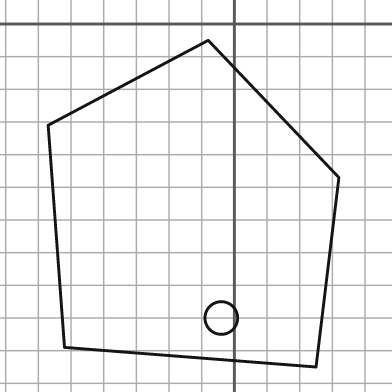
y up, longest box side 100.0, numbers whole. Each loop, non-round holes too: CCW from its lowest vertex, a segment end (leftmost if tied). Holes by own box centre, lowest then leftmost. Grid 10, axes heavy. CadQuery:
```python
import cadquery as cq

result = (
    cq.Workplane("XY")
    .moveTo(25.0, -105.0)
    .lineTo(32.0, -47.0)
    .lineTo(-8.0, -5.0)
    .lineTo(-57.0, -31.0)
    .lineTo(-52.0, -99.0)
    .close()
    .moveTo(-4.0, -90.0)
    .circle(5.0)
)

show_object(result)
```